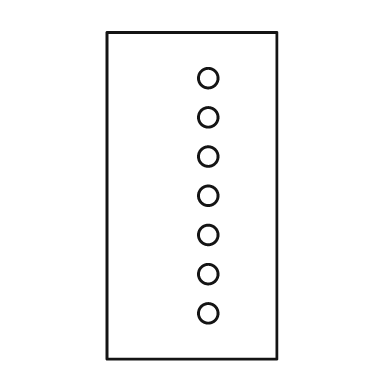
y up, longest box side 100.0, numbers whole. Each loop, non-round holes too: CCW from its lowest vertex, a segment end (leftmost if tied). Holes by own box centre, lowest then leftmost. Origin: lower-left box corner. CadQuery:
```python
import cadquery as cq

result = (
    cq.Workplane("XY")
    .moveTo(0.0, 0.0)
    .lineTo(52.0, 0.0)
    .lineTo(52.0, 100.0)
    .lineTo(0.0, 100.0)
    .close()
    .moveTo(31.0, 14.0)
    .circle(3.0)
    .moveTo(31.0, 26.0)
    .circle(3.0)
    .moveTo(31.0, 38.0)
    .circle(3.0)
    .moveTo(31.0, 50.0)
    .circle(3.0)
    .moveTo(31.0, 62.0)
    .circle(3.0)
    .moveTo(31.0, 74.0)
    .circle(3.0)
    .moveTo(31.0, 86.0)
    .circle(3.0)
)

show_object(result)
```